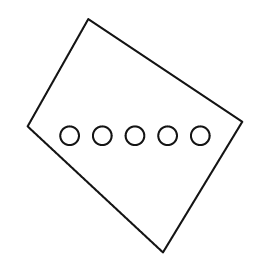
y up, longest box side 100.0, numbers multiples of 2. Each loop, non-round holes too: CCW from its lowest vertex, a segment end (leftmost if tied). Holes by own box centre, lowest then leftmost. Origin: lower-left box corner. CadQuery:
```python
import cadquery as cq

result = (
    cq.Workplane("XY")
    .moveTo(58.0, 0.0)
    .lineTo(92.0, 56.0)
    .lineTo(26.0, 100.0)
    .lineTo(0.0, 54.0)
    .close()
    .moveTo(18.0, 50.0)
    .circle(4.0)
    .moveTo(32.0, 50.0)
    .circle(4.0)
    .moveTo(46.0, 50.0)
    .circle(4.0)
    .moveTo(60.0, 50.0)
    .circle(4.0)
    .moveTo(74.0, 50.0)
    .circle(4.0)
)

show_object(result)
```